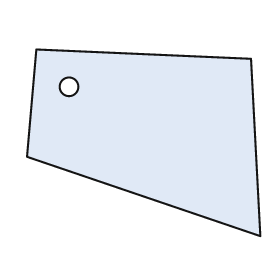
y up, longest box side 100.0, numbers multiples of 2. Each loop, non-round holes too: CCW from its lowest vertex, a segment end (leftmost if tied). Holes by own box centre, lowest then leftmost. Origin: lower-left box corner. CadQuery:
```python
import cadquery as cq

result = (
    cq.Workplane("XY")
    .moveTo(100.0, 0.0)
    .lineTo(96.0, 76.0)
    .lineTo(4.0, 80.0)
    .lineTo(0.0, 34.0)
    .close()
    .moveTo(18.0, 64.0)
    .circle(4.0)
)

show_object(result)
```